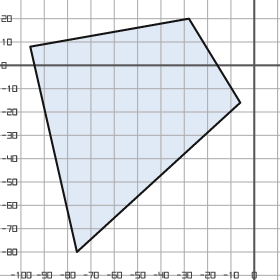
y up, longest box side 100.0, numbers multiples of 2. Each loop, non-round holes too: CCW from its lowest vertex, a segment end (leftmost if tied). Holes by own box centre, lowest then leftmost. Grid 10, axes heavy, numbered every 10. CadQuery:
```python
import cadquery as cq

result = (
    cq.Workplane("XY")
    .moveTo(-76.0, -80.0)
    .lineTo(-6.0, -16.0)
    .lineTo(-28.0, 20.0)
    .lineTo(-96.0, 8.0)
    .close()
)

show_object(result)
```